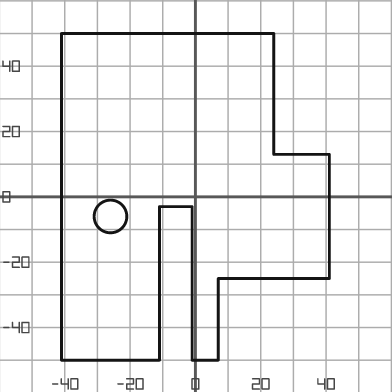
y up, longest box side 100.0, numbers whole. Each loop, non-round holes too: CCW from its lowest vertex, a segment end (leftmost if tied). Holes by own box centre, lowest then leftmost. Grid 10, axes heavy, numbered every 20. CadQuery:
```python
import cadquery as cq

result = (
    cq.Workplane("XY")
    .moveTo(-41.0, -50.0)
    .lineTo(-11.0, -50.0)
    .lineTo(-11.0, -3.0)
    .lineTo(-1.0, -3.0)
    .lineTo(-1.0, -50.0)
    .lineTo(7.0, -50.0)
    .lineTo(7.0, -25.0)
    .lineTo(41.0, -25.0)
    .lineTo(41.0, 13.0)
    .lineTo(24.0, 13.0)
    .lineTo(24.0, 50.0)
    .lineTo(-41.0, 50.0)
    .close()
    .moveTo(-26.0, -6.0)
    .circle(5.0)
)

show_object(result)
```